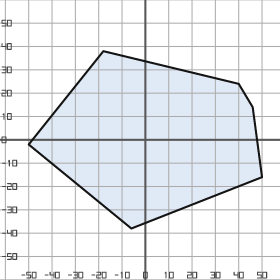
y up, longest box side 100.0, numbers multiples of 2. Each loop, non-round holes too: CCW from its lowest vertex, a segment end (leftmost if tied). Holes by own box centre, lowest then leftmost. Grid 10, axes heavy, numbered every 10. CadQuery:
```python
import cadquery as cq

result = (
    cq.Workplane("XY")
    .moveTo(-6.0, -38.0)
    .lineTo(50.0, -16.0)
    .lineTo(46.0, 14.0)
    .lineTo(40.0, 24.0)
    .lineTo(-18.0, 38.0)
    .lineTo(-50.0, -2.0)
    .close()
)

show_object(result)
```